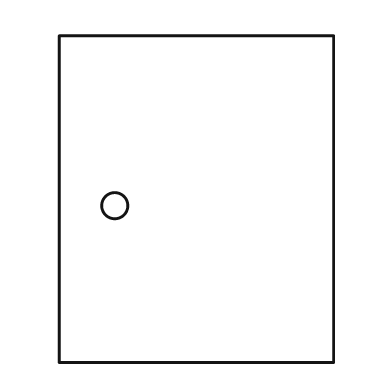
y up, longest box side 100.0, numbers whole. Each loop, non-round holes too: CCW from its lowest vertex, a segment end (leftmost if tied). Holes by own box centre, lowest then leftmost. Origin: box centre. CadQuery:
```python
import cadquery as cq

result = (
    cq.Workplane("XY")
    .moveTo(-42.0, -50.0)
    .lineTo(42.0, -50.0)
    .lineTo(42.0, 50.0)
    .lineTo(-42.0, 50.0)
    .close()
    .moveTo(-25.0, -2.0)
    .circle(4.0)
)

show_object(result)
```